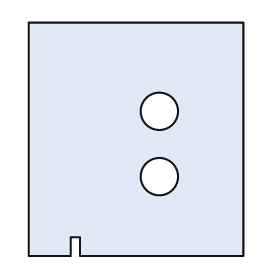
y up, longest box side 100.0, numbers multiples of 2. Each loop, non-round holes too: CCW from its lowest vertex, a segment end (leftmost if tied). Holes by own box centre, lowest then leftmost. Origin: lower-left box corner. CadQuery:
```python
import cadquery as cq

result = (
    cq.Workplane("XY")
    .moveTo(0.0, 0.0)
    .lineTo(18.0, 0.0)
    .lineTo(18.0, 8.0)
    .lineTo(22.0, 8.0)
    .lineTo(22.0, 0.0)
    .lineTo(92.0, 0.0)
    .lineTo(92.0, 100.0)
    .lineTo(0.0, 100.0)
    .close()
    .moveTo(56.0, 34.0)
    .circle(8.0)
    .moveTo(56.0, 62.0)
    .circle(8.0)
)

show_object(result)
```